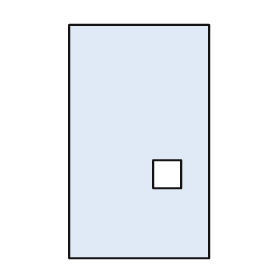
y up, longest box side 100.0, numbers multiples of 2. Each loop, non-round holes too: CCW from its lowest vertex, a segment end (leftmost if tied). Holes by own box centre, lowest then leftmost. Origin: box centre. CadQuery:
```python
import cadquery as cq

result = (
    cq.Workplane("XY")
    .moveTo(-30.0, -50.0)
    .lineTo(30.0, -50.0)
    .lineTo(30.0, 50.0)
    .lineTo(-30.0, 50.0)
    .close()
    .moveTo(6.0, -20.0)
    .lineTo(18.0, -20.0)
    .lineTo(18.0, -8.0)
    .lineTo(6.0, -8.0)
    .close()
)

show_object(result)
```